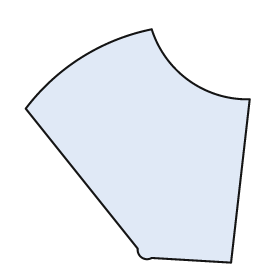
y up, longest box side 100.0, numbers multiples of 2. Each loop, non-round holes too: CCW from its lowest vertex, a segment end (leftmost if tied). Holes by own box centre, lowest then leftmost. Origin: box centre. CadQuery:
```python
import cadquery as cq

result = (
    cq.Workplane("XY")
    .moveTo(40.0, -50.0)
    .lineTo(48.0, 20.0)
    .threePointArc((22.0, 28.0), (6.0, 50.0))
    .threePointArc((-24.0, 38.0), (-48.0, 16.0))
    .lineTo(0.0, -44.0)
    .threePointArc((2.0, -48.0), (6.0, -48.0))
    .close()
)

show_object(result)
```